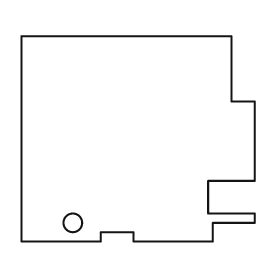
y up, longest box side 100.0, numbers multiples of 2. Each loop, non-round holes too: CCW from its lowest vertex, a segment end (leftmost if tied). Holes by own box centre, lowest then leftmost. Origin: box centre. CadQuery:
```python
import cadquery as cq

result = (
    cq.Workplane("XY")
    .moveTo(-50.0, -44.0)
    .lineTo(-16.0, -44.0)
    .lineTo(-16.0, -40.0)
    .lineTo(-2.0, -40.0)
    .lineTo(-2.0, -44.0)
    .lineTo(32.0, -44.0)
    .lineTo(32.0, -36.0)
    .lineTo(50.0, -36.0)
    .lineTo(50.0, -32.0)
    .lineTo(30.0, -32.0)
    .lineTo(30.0, -18.0)
    .lineTo(50.0, -18.0)
    .lineTo(50.0, 16.0)
    .lineTo(40.0, 16.0)
    .lineTo(40.0, 44.0)
    .lineTo(-50.0, 44.0)
    .close()
    .moveTo(-28.0, -36.0)
    .circle(4.0)
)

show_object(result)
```